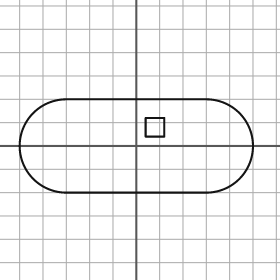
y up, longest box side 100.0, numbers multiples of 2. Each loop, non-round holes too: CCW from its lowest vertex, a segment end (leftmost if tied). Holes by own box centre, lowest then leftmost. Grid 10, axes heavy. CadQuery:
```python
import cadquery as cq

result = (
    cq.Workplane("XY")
    .moveTo(-30.0, -20.0)
    .lineTo(30.0, -20.0)
    .threePointArc((50.0, 0.0), (30.0, 20.0))
    .lineTo(-30.0, 20.0)
    .threePointArc((-50.0, 0.0), (-30.0, -20.0))
    .close()
    .moveTo(4.0, 4.0)
    .lineTo(12.0, 4.0)
    .lineTo(12.0, 12.0)
    .lineTo(4.0, 12.0)
    .close()
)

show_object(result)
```